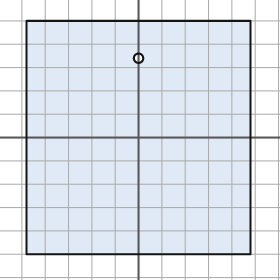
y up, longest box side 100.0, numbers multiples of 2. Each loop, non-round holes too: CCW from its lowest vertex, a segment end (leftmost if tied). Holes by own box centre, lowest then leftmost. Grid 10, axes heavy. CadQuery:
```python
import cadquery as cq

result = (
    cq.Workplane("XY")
    .moveTo(-48.0, -50.0)
    .lineTo(48.0, -50.0)
    .lineTo(48.0, 50.0)
    .lineTo(-48.0, 50.0)
    .close()
    .moveTo(0.0, 34.0)
    .circle(2.0)
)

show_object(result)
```